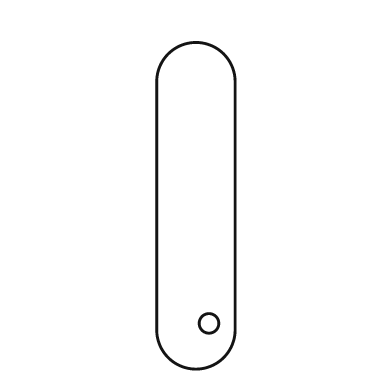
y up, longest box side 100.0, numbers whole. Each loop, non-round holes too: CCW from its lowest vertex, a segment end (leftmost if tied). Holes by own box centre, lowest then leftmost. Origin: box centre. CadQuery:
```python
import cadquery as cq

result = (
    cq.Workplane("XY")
    .moveTo(-12.0, -38.0)
    .threePointArc((0.0, -50.0), (12.0, -38.0))
    .lineTo(12.0, 38.0)
    .threePointArc((0.0, 50.0), (-12.0, 38.0))
    .close()
    .moveTo(4.0, -36.0)
    .circle(3.0)
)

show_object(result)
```